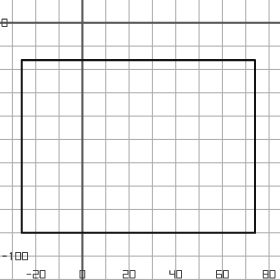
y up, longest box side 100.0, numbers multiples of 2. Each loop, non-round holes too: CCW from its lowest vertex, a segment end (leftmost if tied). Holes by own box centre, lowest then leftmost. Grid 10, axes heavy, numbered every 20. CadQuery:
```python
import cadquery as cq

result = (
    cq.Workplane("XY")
    .moveTo(-26.0, -90.0)
    .lineTo(74.0, -90.0)
    .lineTo(74.0, -16.0)
    .lineTo(-26.0, -16.0)
    .close()
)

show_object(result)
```